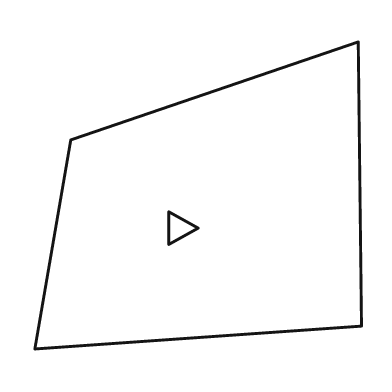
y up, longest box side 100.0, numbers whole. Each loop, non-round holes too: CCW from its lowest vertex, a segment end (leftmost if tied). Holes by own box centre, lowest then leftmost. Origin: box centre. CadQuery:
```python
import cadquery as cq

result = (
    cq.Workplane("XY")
    .moveTo(-50.0, -47.0)
    .lineTo(50.0, -40.0)
    .lineTo(49.0, 47.0)
    .lineTo(-39.0, 17.0)
    .close()
    .moveTo(-9.0, -15.0)
    .lineTo(0.0, -10.0)
    .lineTo(-9.0, -5.0)
    .close()
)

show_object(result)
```